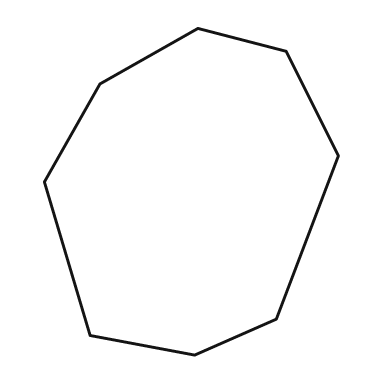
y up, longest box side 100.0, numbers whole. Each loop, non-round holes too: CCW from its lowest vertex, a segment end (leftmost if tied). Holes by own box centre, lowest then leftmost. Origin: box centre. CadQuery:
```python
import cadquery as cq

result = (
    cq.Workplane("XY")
    .moveTo(1.0, -50.0)
    .lineTo(26.0, -39.0)
    .lineTo(45.0, 11.0)
    .lineTo(29.0, 43.0)
    .lineTo(2.0, 50.0)
    .lineTo(-28.0, 33.0)
    .lineTo(-45.0, 3.0)
    .lineTo(-31.0, -44.0)
    .close()
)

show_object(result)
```